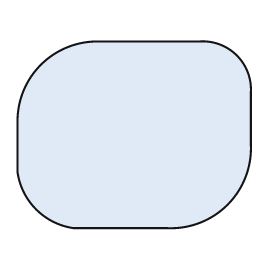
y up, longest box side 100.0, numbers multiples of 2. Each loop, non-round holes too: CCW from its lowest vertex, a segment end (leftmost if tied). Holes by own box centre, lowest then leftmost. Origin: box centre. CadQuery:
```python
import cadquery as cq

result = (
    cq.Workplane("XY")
    .moveTo(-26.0, -40.0)
    .lineTo(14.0, -40.0)
    .threePointArc((40.0, -30.0), (50.0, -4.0))
    .lineTo(50.0, 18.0)
    .threePointArc((44.0, 34.0), (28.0, 40.0))
    .lineTo(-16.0, 40.0)
    .threePointArc((-40.0, 30.0), (-50.0, 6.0))
    .lineTo(-50.0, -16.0)
    .threePointArc((-42.0, -32.0), (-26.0, -40.0))
    .close()
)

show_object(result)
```